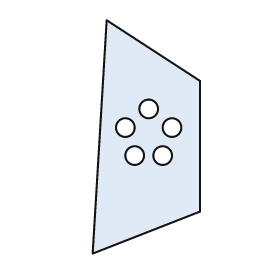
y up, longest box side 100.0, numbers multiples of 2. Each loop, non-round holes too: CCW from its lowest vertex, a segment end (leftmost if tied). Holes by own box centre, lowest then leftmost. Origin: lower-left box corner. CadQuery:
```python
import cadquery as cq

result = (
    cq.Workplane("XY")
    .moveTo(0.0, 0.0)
    .lineTo(46.0, 18.0)
    .lineTo(46.0, 74.0)
    .lineTo(6.0, 100.0)
    .close()
    .moveTo(18.0, 42.0)
    .circle(4.0)
    .moveTo(30.0, 42.0)
    .circle(4.0)
    .moveTo(14.0, 54.0)
    .circle(4.0)
    .moveTo(34.0, 54.0)
    .circle(4.0)
    .moveTo(24.0, 62.0)
    .circle(4.0)
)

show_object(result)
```